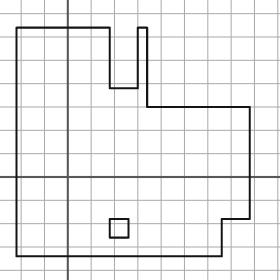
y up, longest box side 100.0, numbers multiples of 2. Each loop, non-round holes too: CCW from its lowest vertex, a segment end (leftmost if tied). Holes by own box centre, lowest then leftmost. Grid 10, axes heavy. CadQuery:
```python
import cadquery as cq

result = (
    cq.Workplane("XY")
    .moveTo(-22.0, -34.0)
    .lineTo(66.0, -34.0)
    .lineTo(66.0, -18.0)
    .lineTo(78.0, -18.0)
    .lineTo(78.0, 30.0)
    .lineTo(34.0, 30.0)
    .lineTo(34.0, 64.0)
    .lineTo(30.0, 64.0)
    .lineTo(30.0, 38.0)
    .lineTo(18.0, 38.0)
    .lineTo(18.0, 64.0)
    .lineTo(-22.0, 64.0)
    .close()
    .moveTo(18.0, -26.0)
    .lineTo(26.0, -26.0)
    .lineTo(26.0, -18.0)
    .lineTo(18.0, -18.0)
    .close()
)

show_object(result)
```